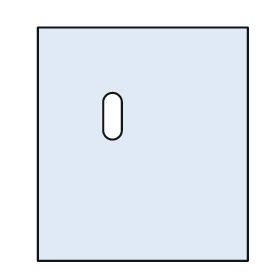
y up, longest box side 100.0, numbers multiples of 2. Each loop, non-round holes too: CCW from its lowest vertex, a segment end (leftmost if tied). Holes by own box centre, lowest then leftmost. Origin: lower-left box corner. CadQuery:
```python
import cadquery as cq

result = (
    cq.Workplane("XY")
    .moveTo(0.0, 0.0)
    .lineTo(90.0, 0.0)
    .lineTo(90.0, 100.0)
    .lineTo(0.0, 100.0)
    .close()
    .moveTo(28.0, 56.0)
    .threePointArc((32.0, 52.0), (36.0, 56.0))
    .lineTo(36.0, 68.0)
    .threePointArc((32.0, 72.0), (28.0, 68.0))
    .close()
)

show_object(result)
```